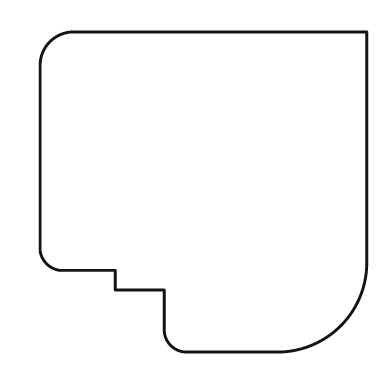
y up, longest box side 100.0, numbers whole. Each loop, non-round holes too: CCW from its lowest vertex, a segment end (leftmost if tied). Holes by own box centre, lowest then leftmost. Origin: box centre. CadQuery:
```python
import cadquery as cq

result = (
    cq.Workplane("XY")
    .moveTo(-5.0, -49.0)
    .lineTo(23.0, -49.0)
    .threePointArc((42.0, -41.0), (50.0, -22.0))
    .lineTo(50.0, 49.0)
    .lineTo(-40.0, 49.0)
    .threePointArc((-47.0, 46.0), (-50.0, 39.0))
    .lineTo(-50.0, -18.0)
    .threePointArc((-48.0, -22.0), (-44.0, -24.0))
    .lineTo(-27.0, -24.0)
    .lineTo(-27.0, -30.0)
    .lineTo(-12.0, -30.0)
    .lineTo(-12.0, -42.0)
    .threePointArc((-10.0, -47.0), (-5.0, -49.0))
    .close()
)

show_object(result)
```